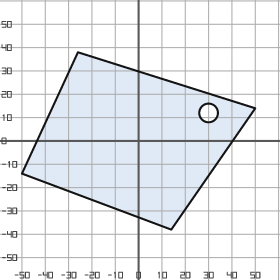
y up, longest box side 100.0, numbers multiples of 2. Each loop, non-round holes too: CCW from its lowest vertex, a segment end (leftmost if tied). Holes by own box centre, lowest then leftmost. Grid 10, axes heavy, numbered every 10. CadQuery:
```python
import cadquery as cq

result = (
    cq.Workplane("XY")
    .moveTo(14.0, -38.0)
    .lineTo(50.0, 14.0)
    .lineTo(-26.0, 38.0)
    .lineTo(-50.0, -14.0)
    .close()
    .moveTo(30.0, 12.0)
    .circle(4.0)
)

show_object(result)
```